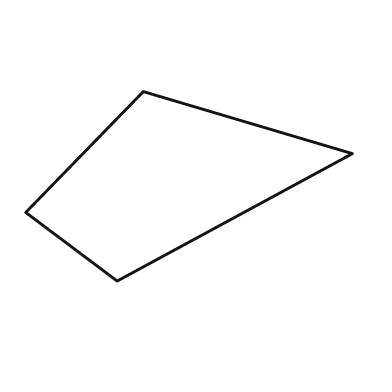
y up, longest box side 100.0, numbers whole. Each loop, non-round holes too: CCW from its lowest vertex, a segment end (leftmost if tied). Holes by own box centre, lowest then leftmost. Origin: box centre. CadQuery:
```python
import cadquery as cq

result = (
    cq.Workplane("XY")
    .moveTo(-22.0, -29.0)
    .lineTo(50.0, 10.0)
    .lineTo(-14.0, 29.0)
    .lineTo(-50.0, -8.0)
    .close()
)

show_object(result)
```